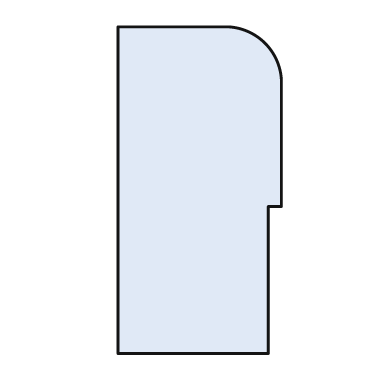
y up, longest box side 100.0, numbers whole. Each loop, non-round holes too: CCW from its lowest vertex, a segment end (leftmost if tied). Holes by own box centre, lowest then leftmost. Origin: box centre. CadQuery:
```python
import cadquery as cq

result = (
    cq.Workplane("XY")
    .moveTo(-25.0, -50.0)
    .lineTo(21.0, -50.0)
    .lineTo(21.0, -5.0)
    .lineTo(25.0, -5.0)
    .lineTo(25.0, 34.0)
    .threePointArc((20.0, 45.0), (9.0, 50.0))
    .lineTo(-25.0, 50.0)
    .close()
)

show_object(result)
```